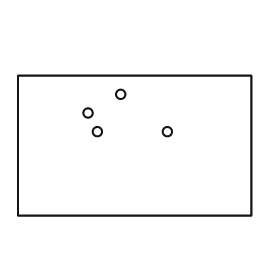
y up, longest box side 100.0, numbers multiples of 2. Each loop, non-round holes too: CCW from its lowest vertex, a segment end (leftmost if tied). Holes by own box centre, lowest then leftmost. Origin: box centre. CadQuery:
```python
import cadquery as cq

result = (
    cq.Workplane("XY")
    .moveTo(-50.0, -30.0)
    .lineTo(50.0, -30.0)
    .lineTo(50.0, 30.0)
    .lineTo(-50.0, 30.0)
    .close()
    .moveTo(-16.0, 6.0)
    .circle(2.0)
    .moveTo(14.0, 6.0)
    .circle(2.0)
    .moveTo(-20.0, 14.0)
    .circle(2.0)
    .moveTo(-6.0, 22.0)
    .circle(2.0)
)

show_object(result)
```